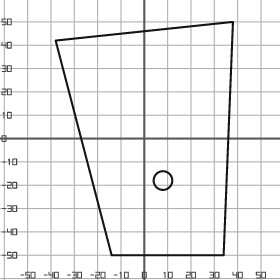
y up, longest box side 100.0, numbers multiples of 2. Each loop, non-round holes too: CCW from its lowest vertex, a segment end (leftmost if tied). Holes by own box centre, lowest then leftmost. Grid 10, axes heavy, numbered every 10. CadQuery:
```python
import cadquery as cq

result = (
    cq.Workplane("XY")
    .moveTo(-14.0, -50.0)
    .lineTo(34.0, -50.0)
    .lineTo(38.0, 50.0)
    .lineTo(-38.0, 42.0)
    .close()
    .moveTo(8.0, -18.0)
    .circle(4.0)
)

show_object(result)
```